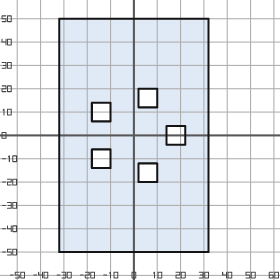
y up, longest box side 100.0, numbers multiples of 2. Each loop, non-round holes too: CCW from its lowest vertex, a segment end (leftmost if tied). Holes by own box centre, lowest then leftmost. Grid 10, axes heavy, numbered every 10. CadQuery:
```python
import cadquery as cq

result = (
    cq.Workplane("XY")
    .moveTo(-32.0, -50.0)
    .lineTo(32.0, -50.0)
    .lineTo(32.0, 50.0)
    .lineTo(-32.0, 50.0)
    .close()
    .moveTo(2.0, -20.0)
    .lineTo(10.0, -20.0)
    .lineTo(10.0, -12.0)
    .lineTo(2.0, -12.0)
    .close()
    .moveTo(-18.0, -14.0)
    .lineTo(-10.0, -14.0)
    .lineTo(-10.0, -6.0)
    .lineTo(-18.0, -6.0)
    .close()
    .moveTo(14.0, -4.0)
    .lineTo(22.0, -4.0)
    .lineTo(22.0, 4.0)
    .lineTo(14.0, 4.0)
    .close()
    .moveTo(-18.0, 6.0)
    .lineTo(-10.0, 6.0)
    .lineTo(-10.0, 14.0)
    .lineTo(-18.0, 14.0)
    .close()
    .moveTo(2.0, 12.0)
    .lineTo(10.0, 12.0)
    .lineTo(10.0, 20.0)
    .lineTo(2.0, 20.0)
    .close()
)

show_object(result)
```